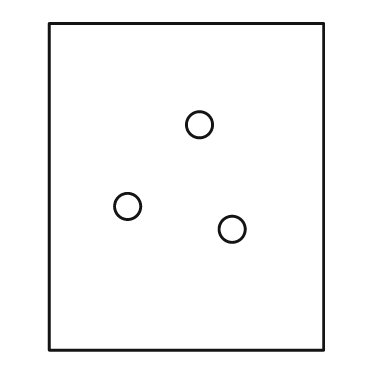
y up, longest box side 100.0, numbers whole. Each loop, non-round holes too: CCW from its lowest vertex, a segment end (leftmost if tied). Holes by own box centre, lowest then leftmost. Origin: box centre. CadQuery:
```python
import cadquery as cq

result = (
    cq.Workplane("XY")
    .moveTo(-42.0, -50.0)
    .lineTo(42.0, -50.0)
    .lineTo(42.0, 50.0)
    .lineTo(-42.0, 50.0)
    .close()
    .moveTo(14.0, -13.0)
    .circle(4.0)
    .moveTo(-18.0, -6.0)
    .circle(4.0)
    .moveTo(4.0, 19.0)
    .circle(4.0)
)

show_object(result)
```